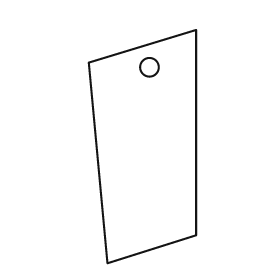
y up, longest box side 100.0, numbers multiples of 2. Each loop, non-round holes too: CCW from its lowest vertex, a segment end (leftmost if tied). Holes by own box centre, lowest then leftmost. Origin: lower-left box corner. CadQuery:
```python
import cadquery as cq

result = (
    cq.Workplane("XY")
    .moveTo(8.0, 0.0)
    .lineTo(46.0, 12.0)
    .lineTo(46.0, 100.0)
    .lineTo(0.0, 86.0)
    .close()
    .moveTo(26.0, 84.0)
    .circle(4.0)
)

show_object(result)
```